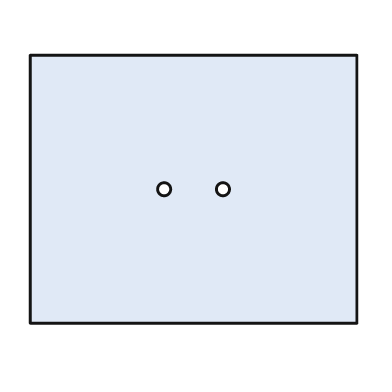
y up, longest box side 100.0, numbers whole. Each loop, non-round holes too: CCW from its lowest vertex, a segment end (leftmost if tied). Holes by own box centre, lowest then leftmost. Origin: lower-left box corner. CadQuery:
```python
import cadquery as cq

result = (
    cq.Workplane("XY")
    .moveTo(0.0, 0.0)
    .lineTo(100.0, 0.0)
    .lineTo(100.0, 82.0)
    .lineTo(0.0, 82.0)
    .close()
    .moveTo(41.0, 41.0)
    .circle(2.0)
    .moveTo(59.0, 41.0)
    .circle(2.0)
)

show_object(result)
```